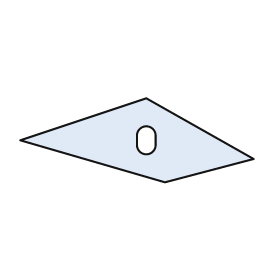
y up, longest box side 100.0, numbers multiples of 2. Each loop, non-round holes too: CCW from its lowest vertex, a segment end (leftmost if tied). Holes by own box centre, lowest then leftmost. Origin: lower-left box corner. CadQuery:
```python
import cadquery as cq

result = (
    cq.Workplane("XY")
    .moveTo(62.0, 0.0)
    .lineTo(100.0, 10.0)
    .lineTo(54.0, 36.0)
    .lineTo(0.0, 18.0)
    .close()
    .moveTo(50.0, 16.0)
    .threePointArc((54.0, 12.0), (58.0, 16.0))
    .lineTo(58.0, 20.0)
    .threePointArc((54.0, 24.0), (50.0, 20.0))
    .close()
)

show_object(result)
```